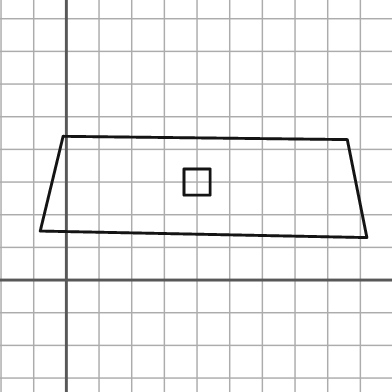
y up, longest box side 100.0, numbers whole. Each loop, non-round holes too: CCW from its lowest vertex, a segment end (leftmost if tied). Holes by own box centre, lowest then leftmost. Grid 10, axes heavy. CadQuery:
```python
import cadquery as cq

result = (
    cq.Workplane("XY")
    .moveTo(92.0, 13.0)
    .lineTo(86.0, 43.0)
    .lineTo(-1.0, 44.0)
    .lineTo(-8.0, 15.0)
    .close()
    .moveTo(36.0, 26.0)
    .lineTo(44.0, 26.0)
    .lineTo(44.0, 34.0)
    .lineTo(36.0, 34.0)
    .close()
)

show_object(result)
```